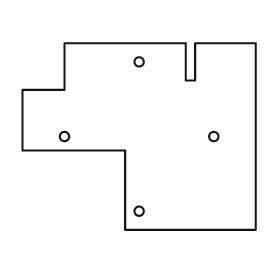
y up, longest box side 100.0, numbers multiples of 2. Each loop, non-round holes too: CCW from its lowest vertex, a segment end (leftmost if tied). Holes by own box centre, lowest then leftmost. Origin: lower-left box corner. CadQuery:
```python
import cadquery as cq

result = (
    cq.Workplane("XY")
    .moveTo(44.0, 0.0)
    .lineTo(100.0, 0.0)
    .lineTo(100.0, 80.0)
    .lineTo(74.0, 80.0)
    .lineTo(74.0, 64.0)
    .lineTo(70.0, 64.0)
    .lineTo(70.0, 80.0)
    .lineTo(18.0, 80.0)
    .lineTo(18.0, 60.0)
    .lineTo(0.0, 60.0)
    .lineTo(0.0, 34.0)
    .lineTo(44.0, 34.0)
    .close()
    .moveTo(50.0, 8.0)
    .circle(2.0)
    .moveTo(18.0, 40.0)
    .circle(2.0)
    .moveTo(82.0, 40.0)
    .circle(2.0)
    .moveTo(50.0, 72.0)
    .circle(2.0)
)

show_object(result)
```